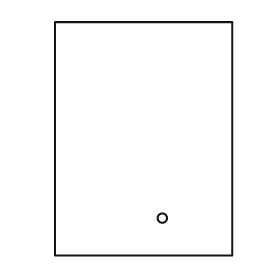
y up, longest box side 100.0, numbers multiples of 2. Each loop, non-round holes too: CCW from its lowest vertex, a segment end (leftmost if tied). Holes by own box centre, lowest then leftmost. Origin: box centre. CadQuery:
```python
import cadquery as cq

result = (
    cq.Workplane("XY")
    .moveTo(-38.0, -50.0)
    .lineTo(38.0, -50.0)
    .lineTo(38.0, 50.0)
    .lineTo(-38.0, 50.0)
    .close()
    .moveTo(8.0, -34.0)
    .circle(2.0)
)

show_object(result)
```